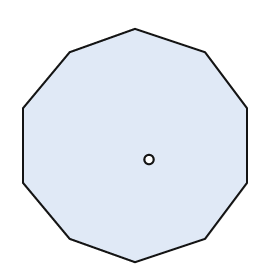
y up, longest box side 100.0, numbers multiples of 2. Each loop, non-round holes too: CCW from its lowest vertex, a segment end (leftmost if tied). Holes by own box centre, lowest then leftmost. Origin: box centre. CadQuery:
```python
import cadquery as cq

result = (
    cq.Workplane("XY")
    .moveTo(0.0, -50.0)
    .lineTo(30.0, -40.0)
    .lineTo(48.0, -16.0)
    .lineTo(48.0, 16.0)
    .lineTo(30.0, 40.0)
    .lineTo(0.0, 50.0)
    .lineTo(-28.0, 40.0)
    .lineTo(-48.0, 16.0)
    .lineTo(-48.0, -16.0)
    .lineTo(-28.0, -40.0)
    .close()
    .moveTo(6.0, -6.0)
    .circle(2.0)
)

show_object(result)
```